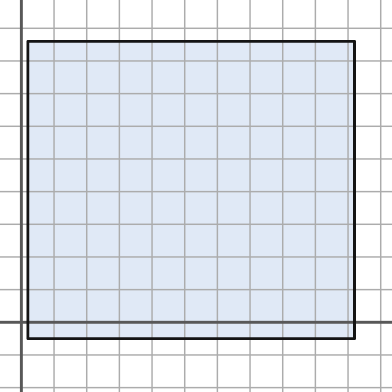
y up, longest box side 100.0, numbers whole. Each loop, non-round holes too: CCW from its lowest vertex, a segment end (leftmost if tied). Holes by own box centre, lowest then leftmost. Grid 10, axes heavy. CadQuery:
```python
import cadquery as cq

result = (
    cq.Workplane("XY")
    .moveTo(2.0, -5.0)
    .lineTo(102.0, -5.0)
    .lineTo(102.0, 86.0)
    .lineTo(2.0, 86.0)
    .close()
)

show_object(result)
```